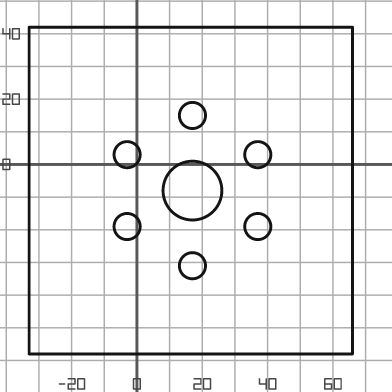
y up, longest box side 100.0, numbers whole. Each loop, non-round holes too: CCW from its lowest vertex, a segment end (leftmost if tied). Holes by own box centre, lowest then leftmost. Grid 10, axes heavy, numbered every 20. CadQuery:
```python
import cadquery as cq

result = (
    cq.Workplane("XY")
    .moveTo(-33.0, -58.0)
    .lineTo(66.0, -58.0)
    .lineTo(66.0, 42.0)
    .lineTo(-33.0, 42.0)
    .close()
    .moveTo(17.0, -31.0)
    .circle(4.0)
    .moveTo(-3.0, -19.0)
    .circle(4.0)
    .moveTo(37.0, -19.0)
    .circle(4.0)
    .moveTo(17.0, -8.0)
    .circle(9.0)
    .moveTo(-3.0, 3.0)
    .circle(4.0)
    .moveTo(37.0, 3.0)
    .circle(4.0)
    .moveTo(17.0, 15.0)
    .circle(4.0)
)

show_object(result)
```